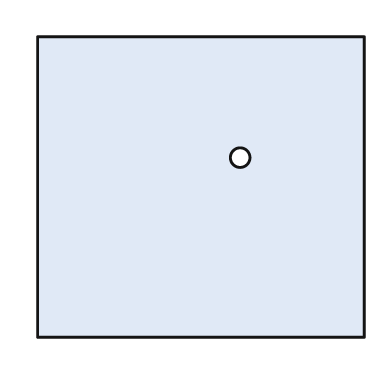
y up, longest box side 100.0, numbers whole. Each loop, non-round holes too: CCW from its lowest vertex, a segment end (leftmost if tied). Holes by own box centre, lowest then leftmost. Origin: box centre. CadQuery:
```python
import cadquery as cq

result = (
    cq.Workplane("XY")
    .moveTo(-50.0, -46.0)
    .lineTo(50.0, -46.0)
    .lineTo(50.0, 46.0)
    .lineTo(-50.0, 46.0)
    .close()
    .moveTo(12.0, 9.0)
    .circle(3.0)
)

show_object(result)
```